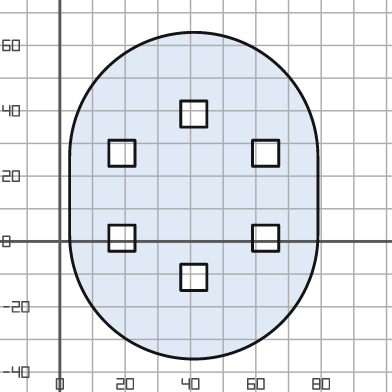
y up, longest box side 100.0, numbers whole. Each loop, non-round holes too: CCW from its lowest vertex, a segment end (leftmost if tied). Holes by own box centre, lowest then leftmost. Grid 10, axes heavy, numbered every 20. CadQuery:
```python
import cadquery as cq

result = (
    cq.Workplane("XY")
    .moveTo(3.0, 2.0)
    .threePointArc((41.0, -36.0), (79.0, 2.0))
    .lineTo(79.0, 26.0)
    .threePointArc((41.0, 64.0), (3.0, 26.0))
    .close()
    .moveTo(37.0, -15.0)
    .lineTo(45.0, -15.0)
    .lineTo(45.0, -7.0)
    .lineTo(37.0, -7.0)
    .close()
    .moveTo(15.0, -3.0)
    .lineTo(23.0, -3.0)
    .lineTo(23.0, 5.0)
    .lineTo(15.0, 5.0)
    .close()
    .moveTo(59.0, -3.0)
    .lineTo(67.0, -3.0)
    .lineTo(67.0, 5.0)
    .lineTo(59.0, 5.0)
    .close()
    .moveTo(15.0, 23.0)
    .lineTo(23.0, 23.0)
    .lineTo(23.0, 31.0)
    .lineTo(15.0, 31.0)
    .close()
    .moveTo(59.0, 23.0)
    .lineTo(67.0, 23.0)
    .lineTo(67.0, 31.0)
    .lineTo(59.0, 31.0)
    .close()
    .moveTo(37.0, 35.0)
    .lineTo(45.0, 35.0)
    .lineTo(45.0, 43.0)
    .lineTo(37.0, 43.0)
    .close()
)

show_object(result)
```